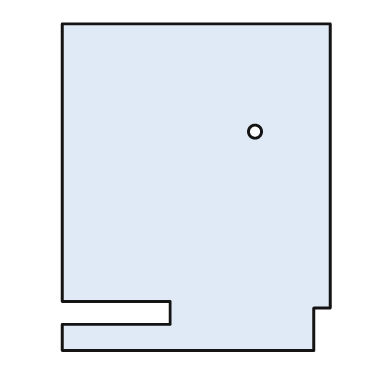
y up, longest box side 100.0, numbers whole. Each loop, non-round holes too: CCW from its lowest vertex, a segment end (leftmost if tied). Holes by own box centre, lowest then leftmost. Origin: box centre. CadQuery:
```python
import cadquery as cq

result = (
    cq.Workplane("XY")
    .moveTo(-41.0, -50.0)
    .lineTo(36.0, -50.0)
    .lineTo(36.0, -37.0)
    .lineTo(41.0, -37.0)
    .lineTo(41.0, 50.0)
    .lineTo(-41.0, 50.0)
    .lineTo(-41.0, -35.0)
    .lineTo(-8.0, -35.0)
    .lineTo(-8.0, -42.0)
    .lineTo(-41.0, -42.0)
    .close()
    .moveTo(18.0, 17.0)
    .circle(2.0)
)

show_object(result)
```